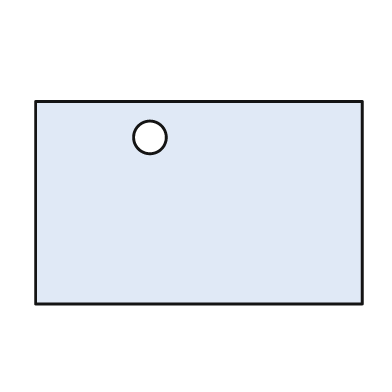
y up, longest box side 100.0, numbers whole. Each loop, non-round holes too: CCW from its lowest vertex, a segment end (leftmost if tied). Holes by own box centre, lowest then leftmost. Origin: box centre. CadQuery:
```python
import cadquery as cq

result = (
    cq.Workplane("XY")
    .moveTo(-50.0, -31.0)
    .lineTo(50.0, -31.0)
    .lineTo(50.0, 31.0)
    .lineTo(-50.0, 31.0)
    .close()
    .moveTo(-15.0, 20.0)
    .circle(5.0)
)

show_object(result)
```